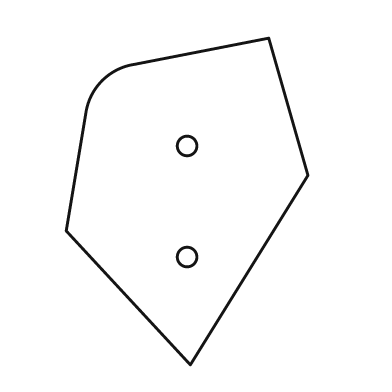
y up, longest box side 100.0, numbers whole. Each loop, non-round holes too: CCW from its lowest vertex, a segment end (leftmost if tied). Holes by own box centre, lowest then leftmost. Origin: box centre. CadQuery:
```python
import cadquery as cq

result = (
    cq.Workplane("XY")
    .moveTo(1.0, -50.0)
    .lineTo(37.0, 8.0)
    .lineTo(25.0, 50.0)
    .lineTo(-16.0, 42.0)
    .threePointArc((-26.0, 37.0), (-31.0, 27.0))
    .lineTo(-37.0, -9.0)
    .close()
    .moveTo(0.0, -17.0)
    .circle(3.0)
    .moveTo(0.0, 17.0)
    .circle(3.0)
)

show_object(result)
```